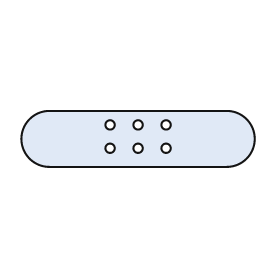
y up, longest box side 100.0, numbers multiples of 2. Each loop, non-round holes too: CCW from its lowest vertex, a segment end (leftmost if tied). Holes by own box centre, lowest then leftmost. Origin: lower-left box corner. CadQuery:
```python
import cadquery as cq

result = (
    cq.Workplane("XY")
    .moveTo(12.0, 0.0)
    .lineTo(88.0, 0.0)
    .threePointArc((100.0, 12.0), (88.0, 24.0))
    .lineTo(12.0, 24.0)
    .threePointArc((0.0, 12.0), (12.0, 0.0))
    .close()
    .moveTo(38.0, 8.0)
    .circle(2.0)
    .moveTo(50.0, 8.0)
    .circle(2.0)
    .moveTo(62.0, 8.0)
    .circle(2.0)
    .moveTo(38.0, 18.0)
    .circle(2.0)
    .moveTo(50.0, 18.0)
    .circle(2.0)
    .moveTo(62.0, 18.0)
    .circle(2.0)
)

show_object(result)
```